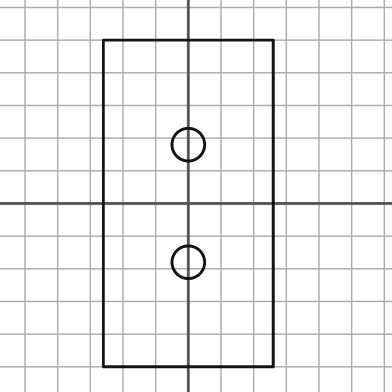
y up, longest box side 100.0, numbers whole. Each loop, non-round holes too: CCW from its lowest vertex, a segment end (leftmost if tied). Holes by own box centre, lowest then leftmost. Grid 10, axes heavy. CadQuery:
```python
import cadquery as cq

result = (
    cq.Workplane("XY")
    .moveTo(-26.0, -50.0)
    .lineTo(26.0, -50.0)
    .lineTo(26.0, 50.0)
    .lineTo(-26.0, 50.0)
    .close()
    .moveTo(0.0, -18.0)
    .circle(5.0)
    .moveTo(0.0, 18.0)
    .circle(5.0)
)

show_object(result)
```